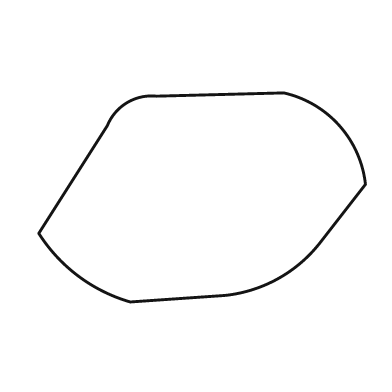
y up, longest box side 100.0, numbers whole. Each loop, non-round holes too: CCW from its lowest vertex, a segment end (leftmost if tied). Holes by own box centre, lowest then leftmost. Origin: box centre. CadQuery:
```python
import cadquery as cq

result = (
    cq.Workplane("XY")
    .moveTo(-22.0, -32.0)
    .lineTo(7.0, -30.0)
    .threePointArc((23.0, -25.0), (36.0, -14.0))
    .lineTo(50.0, 4.0)
    .threePointArc((42.0, 22.0), (25.0, 32.0))
    .lineTo(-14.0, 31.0)
    .threePointArc((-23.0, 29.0), (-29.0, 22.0))
    .lineTo(-50.0, -11.0)
    .threePointArc((-38.0, -24.0), (-22.0, -32.0))
    .close()
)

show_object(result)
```